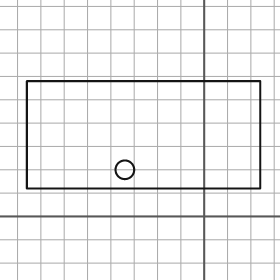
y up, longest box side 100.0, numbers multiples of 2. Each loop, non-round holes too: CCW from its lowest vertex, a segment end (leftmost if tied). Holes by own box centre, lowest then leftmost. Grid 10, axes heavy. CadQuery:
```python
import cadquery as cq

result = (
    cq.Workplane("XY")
    .moveTo(-76.0, 12.0)
    .lineTo(24.0, 12.0)
    .lineTo(24.0, 58.0)
    .lineTo(-76.0, 58.0)
    .close()
    .moveTo(-34.0, 20.0)
    .circle(4.0)
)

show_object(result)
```